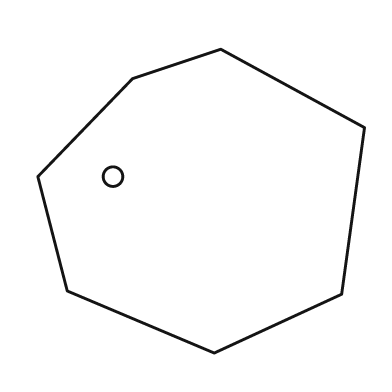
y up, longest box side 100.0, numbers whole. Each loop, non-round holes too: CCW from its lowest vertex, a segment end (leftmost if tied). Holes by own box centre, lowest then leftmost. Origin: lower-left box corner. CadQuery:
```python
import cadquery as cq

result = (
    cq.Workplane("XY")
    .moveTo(54.0, 0.0)
    .lineTo(93.0, 18.0)
    .lineTo(100.0, 69.0)
    .lineTo(56.0, 93.0)
    .lineTo(29.0, 84.0)
    .lineTo(0.0, 54.0)
    .lineTo(9.0, 19.0)
    .close()
    .moveTo(23.0, 54.0)
    .circle(3.0)
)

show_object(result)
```